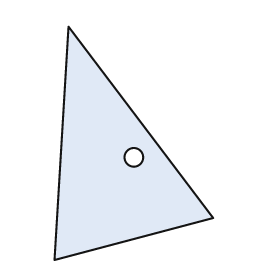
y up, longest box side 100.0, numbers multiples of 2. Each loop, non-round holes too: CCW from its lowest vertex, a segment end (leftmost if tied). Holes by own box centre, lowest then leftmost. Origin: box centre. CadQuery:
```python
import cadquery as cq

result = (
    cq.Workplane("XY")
    .moveTo(-34.0, -50.0)
    .lineTo(34.0, -32.0)
    .lineTo(-28.0, 50.0)
    .close()
    .moveTo(0.0, -6.0)
    .circle(4.0)
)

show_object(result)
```